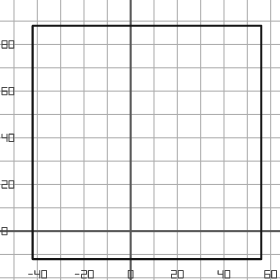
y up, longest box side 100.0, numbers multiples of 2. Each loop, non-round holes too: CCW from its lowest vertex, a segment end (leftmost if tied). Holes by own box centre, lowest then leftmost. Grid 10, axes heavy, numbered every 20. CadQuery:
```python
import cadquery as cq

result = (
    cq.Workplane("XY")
    .moveTo(-42.0, -12.0)
    .lineTo(56.0, -12.0)
    .lineTo(56.0, 88.0)
    .lineTo(-42.0, 88.0)
    .close()
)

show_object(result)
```